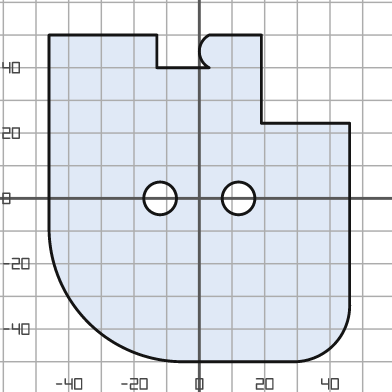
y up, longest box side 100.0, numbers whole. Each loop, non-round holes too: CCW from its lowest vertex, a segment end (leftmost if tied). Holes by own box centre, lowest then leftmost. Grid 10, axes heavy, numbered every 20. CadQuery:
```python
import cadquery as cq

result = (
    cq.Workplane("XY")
    .moveTo(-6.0, -50.0)
    .lineTo(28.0, -50.0)
    .threePointArc((41.0, -45.0), (46.0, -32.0))
    .lineTo(46.0, 23.0)
    .lineTo(19.0, 23.0)
    .lineTo(19.0, 50.0)
    .lineTo(3.0, 50.0)
    .threePointArc((0.0, 45.0), (3.0, 40.0))
    .lineTo(-13.0, 40.0)
    .lineTo(-13.0, 50.0)
    .lineTo(-46.0, 50.0)
    .lineTo(-46.0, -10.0)
    .threePointArc((-34.0, -38.0), (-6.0, -50.0))
    .close()
    .moveTo(-12.0, 0.0)
    .circle(5.0)
    .moveTo(12.0, 0.0)
    .circle(5.0)
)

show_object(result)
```